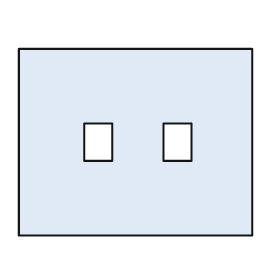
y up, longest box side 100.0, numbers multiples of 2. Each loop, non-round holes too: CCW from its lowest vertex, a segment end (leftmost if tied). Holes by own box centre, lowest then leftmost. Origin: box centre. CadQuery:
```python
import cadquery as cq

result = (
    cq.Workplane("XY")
    .moveTo(-50.0, -40.0)
    .lineTo(50.0, -40.0)
    .lineTo(50.0, 40.0)
    .lineTo(-50.0, 40.0)
    .close()
    .moveTo(-22.0, -8.0)
    .lineTo(-10.0, -8.0)
    .lineTo(-10.0, 8.0)
    .lineTo(-22.0, 8.0)
    .close()
    .moveTo(12.0, -8.0)
    .lineTo(24.0, -8.0)
    .lineTo(24.0, 8.0)
    .lineTo(12.0, 8.0)
    .close()
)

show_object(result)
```